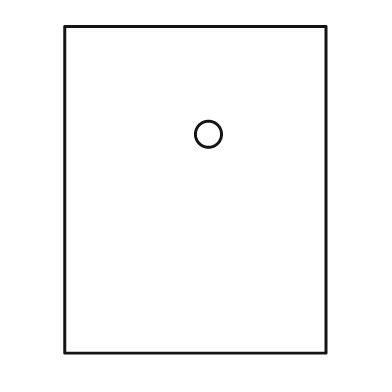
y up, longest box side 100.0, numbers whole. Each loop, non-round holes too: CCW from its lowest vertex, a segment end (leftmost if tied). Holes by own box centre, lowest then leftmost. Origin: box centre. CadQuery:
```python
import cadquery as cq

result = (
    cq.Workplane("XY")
    .moveTo(-40.0, -50.0)
    .lineTo(40.0, -50.0)
    .lineTo(40.0, 50.0)
    .lineTo(-40.0, 50.0)
    .close()
    .moveTo(4.0, 17.0)
    .circle(4.0)
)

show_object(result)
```